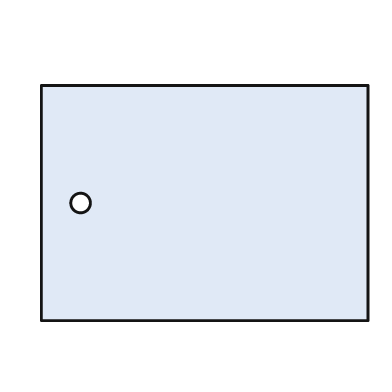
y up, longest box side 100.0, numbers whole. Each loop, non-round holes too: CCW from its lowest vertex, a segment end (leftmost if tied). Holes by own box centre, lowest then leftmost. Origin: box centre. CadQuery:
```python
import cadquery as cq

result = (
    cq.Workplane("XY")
    .moveTo(-50.0, -36.0)
    .lineTo(50.0, -36.0)
    .lineTo(50.0, 36.0)
    .lineTo(-50.0, 36.0)
    .close()
    .moveTo(-38.0, 0.0)
    .circle(3.0)
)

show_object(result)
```